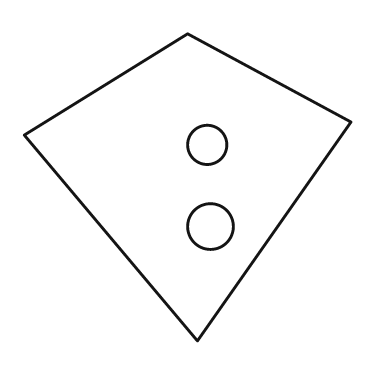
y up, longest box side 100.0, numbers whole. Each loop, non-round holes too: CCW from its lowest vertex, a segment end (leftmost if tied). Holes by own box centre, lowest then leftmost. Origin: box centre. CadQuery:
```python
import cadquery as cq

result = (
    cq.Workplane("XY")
    .moveTo(3.0, -47.0)
    .lineTo(50.0, 20.0)
    .lineTo(0.0, 47.0)
    .lineTo(-50.0, 16.0)
    .close()
    .moveTo(7.0, -12.0)
    .circle(7.0)
    .moveTo(6.0, 13.0)
    .circle(6.0)
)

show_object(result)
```